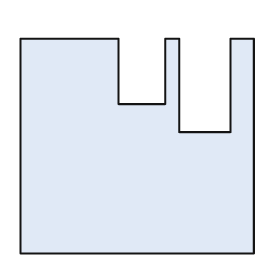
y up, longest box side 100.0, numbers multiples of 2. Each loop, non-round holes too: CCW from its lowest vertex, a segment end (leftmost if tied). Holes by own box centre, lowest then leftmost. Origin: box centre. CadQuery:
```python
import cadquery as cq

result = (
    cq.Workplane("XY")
    .moveTo(-50.0, -46.0)
    .lineTo(50.0, -46.0)
    .lineTo(50.0, 46.0)
    .lineTo(40.0, 46.0)
    .lineTo(40.0, 6.0)
    .lineTo(18.0, 6.0)
    .lineTo(18.0, 46.0)
    .lineTo(12.0, 46.0)
    .lineTo(12.0, 18.0)
    .lineTo(-8.0, 18.0)
    .lineTo(-8.0, 46.0)
    .lineTo(-50.0, 46.0)
    .close()
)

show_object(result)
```